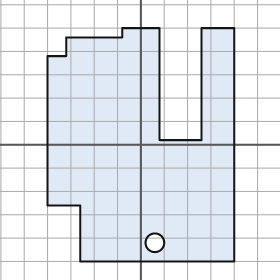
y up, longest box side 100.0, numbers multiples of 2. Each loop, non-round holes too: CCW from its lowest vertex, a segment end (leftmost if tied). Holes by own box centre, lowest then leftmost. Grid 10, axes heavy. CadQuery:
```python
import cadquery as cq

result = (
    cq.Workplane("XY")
    .moveTo(-26.0, -50.0)
    .lineTo(40.0, -50.0)
    .lineTo(40.0, 50.0)
    .lineTo(26.0, 50.0)
    .lineTo(26.0, 2.0)
    .lineTo(8.0, 2.0)
    .lineTo(8.0, 50.0)
    .lineTo(-8.0, 50.0)
    .lineTo(-8.0, 46.0)
    .lineTo(-32.0, 46.0)
    .lineTo(-32.0, 38.0)
    .lineTo(-40.0, 38.0)
    .lineTo(-40.0, -26.0)
    .lineTo(-26.0, -26.0)
    .close()
    .moveTo(6.0, -42.0)
    .circle(4.0)
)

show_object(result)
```